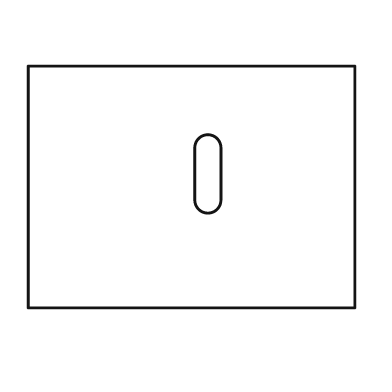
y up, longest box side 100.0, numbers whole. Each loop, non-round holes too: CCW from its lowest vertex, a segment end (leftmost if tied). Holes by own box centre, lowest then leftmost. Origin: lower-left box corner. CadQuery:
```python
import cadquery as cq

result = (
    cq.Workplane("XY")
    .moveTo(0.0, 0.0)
    .lineTo(100.0, 0.0)
    .lineTo(100.0, 74.0)
    .lineTo(0.0, 74.0)
    .close()
    .moveTo(51.0, 33.0)
    .threePointArc((55.0, 29.0), (59.0, 33.0))
    .lineTo(59.0, 49.0)
    .threePointArc((55.0, 53.0), (51.0, 49.0))
    .close()
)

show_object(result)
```